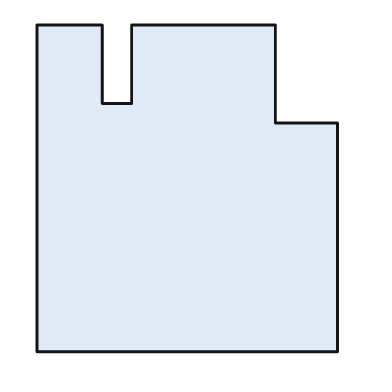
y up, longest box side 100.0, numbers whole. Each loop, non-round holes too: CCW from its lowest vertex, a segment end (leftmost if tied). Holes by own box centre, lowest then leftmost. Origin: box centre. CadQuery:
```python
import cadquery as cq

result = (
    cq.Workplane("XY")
    .moveTo(-46.0, -50.0)
    .lineTo(46.0, -50.0)
    .lineTo(46.0, 20.0)
    .lineTo(27.0, 20.0)
    .lineTo(27.0, 50.0)
    .lineTo(-17.0, 50.0)
    .lineTo(-17.0, 26.0)
    .lineTo(-26.0, 26.0)
    .lineTo(-26.0, 50.0)
    .lineTo(-46.0, 50.0)
    .close()
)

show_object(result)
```